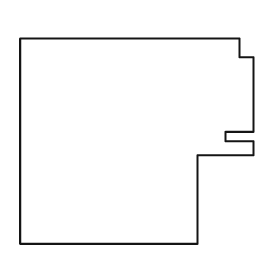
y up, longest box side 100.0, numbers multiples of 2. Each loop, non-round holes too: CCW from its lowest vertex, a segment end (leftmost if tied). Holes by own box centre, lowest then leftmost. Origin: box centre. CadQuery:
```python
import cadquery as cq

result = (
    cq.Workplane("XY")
    .moveTo(-50.0, -44.0)
    .lineTo(26.0, -44.0)
    .lineTo(26.0, -6.0)
    .lineTo(50.0, -6.0)
    .lineTo(50.0, 0.0)
    .lineTo(38.0, 0.0)
    .lineTo(38.0, 4.0)
    .lineTo(50.0, 4.0)
    .lineTo(50.0, 36.0)
    .lineTo(44.0, 36.0)
    .lineTo(44.0, 44.0)
    .lineTo(-50.0, 44.0)
    .close()
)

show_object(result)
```